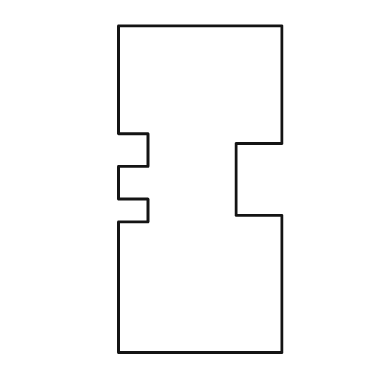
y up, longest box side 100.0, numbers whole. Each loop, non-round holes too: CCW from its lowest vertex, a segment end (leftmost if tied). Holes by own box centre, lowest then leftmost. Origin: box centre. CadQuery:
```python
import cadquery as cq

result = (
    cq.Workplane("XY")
    .moveTo(-25.0, -50.0)
    .lineTo(25.0, -50.0)
    .lineTo(25.0, -8.0)
    .lineTo(11.0, -8.0)
    .lineTo(11.0, 14.0)
    .lineTo(25.0, 14.0)
    .lineTo(25.0, 50.0)
    .lineTo(-25.0, 50.0)
    .lineTo(-25.0, 17.0)
    .lineTo(-16.0, 17.0)
    .lineTo(-16.0, 7.0)
    .lineTo(-25.0, 7.0)
    .lineTo(-25.0, -3.0)
    .lineTo(-16.0, -3.0)
    .lineTo(-16.0, -10.0)
    .lineTo(-25.0, -10.0)
    .close()
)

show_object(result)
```